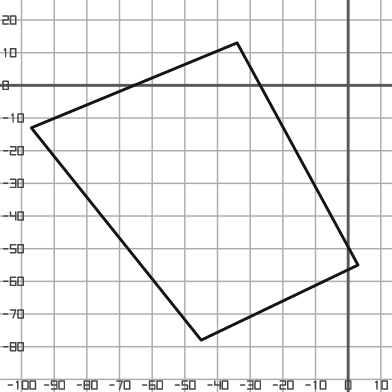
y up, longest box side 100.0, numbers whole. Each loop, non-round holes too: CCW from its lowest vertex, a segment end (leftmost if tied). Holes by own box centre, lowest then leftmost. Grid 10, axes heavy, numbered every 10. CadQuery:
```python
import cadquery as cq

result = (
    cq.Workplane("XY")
    .moveTo(-45.0, -78.0)
    .lineTo(3.0, -55.0)
    .lineTo(-34.0, 13.0)
    .lineTo(-97.0, -13.0)
    .close()
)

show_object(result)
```